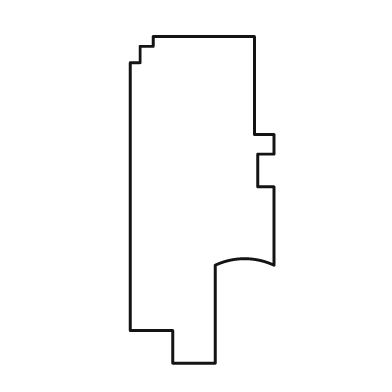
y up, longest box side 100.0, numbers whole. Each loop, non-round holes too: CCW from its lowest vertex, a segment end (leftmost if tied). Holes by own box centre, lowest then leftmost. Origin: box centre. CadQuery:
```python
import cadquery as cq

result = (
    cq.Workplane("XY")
    .moveTo(-9.0, -50.0)
    .lineTo(4.0, -50.0)
    .lineTo(4.0, -20.0)
    .threePointArc((13.0, -18.0), (22.0, -20.0))
    .lineTo(22.0, 4.0)
    .lineTo(17.0, 4.0)
    .lineTo(17.0, 14.0)
    .lineTo(22.0, 14.0)
    .lineTo(22.0, 20.0)
    .lineTo(16.0, 20.0)
    .lineTo(16.0, 50.0)
    .lineTo(-15.0, 50.0)
    .lineTo(-15.0, 47.0)
    .lineTo(-19.0, 47.0)
    .lineTo(-19.0, 42.0)
    .lineTo(-22.0, 42.0)
    .lineTo(-22.0, -40.0)
    .lineTo(-9.0, -40.0)
    .close()
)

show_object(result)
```